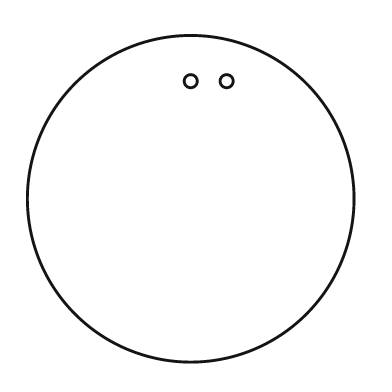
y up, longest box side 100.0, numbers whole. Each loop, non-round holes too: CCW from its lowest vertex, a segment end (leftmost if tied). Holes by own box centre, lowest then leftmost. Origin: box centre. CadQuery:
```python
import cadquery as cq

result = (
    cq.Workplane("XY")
    .moveTo(0.0, 0.0)
    .circle(50.0)
    .moveTo(0.0, 36.0)
    .circle(2.0)
    .moveTo(11.0, 36.0)
    .circle(2.0)
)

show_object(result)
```